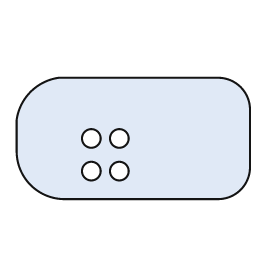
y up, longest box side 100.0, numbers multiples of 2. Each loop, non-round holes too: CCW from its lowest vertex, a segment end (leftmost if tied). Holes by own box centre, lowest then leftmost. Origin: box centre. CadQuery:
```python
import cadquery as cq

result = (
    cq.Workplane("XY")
    .moveTo(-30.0, -26.0)
    .lineTo(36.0, -26.0)
    .threePointArc((46.0, -22.0), (50.0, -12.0))
    .lineTo(50.0, 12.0)
    .threePointArc((46.0, 22.0), (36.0, 26.0))
    .lineTo(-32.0, 26.0)
    .threePointArc((-44.0, 20.0), (-50.0, 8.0))
    .lineTo(-50.0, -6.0)
    .threePointArc((-44.0, -20.0), (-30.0, -26.0))
    .close()
    .moveTo(-18.0, -14.0)
    .circle(4.0)
    .moveTo(-6.0, -14.0)
    .circle(4.0)
    .moveTo(-18.0, 0.0)
    .circle(4.0)
    .moveTo(-6.0, 0.0)
    .circle(4.0)
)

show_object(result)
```